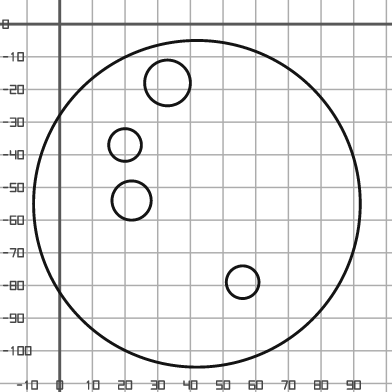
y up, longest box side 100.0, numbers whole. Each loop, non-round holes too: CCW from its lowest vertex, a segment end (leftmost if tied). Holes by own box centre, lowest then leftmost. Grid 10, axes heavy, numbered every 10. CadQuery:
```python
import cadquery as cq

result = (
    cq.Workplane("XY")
    .moveTo(42.0, -55.0)
    .circle(50.0)
    .moveTo(56.0, -79.0)
    .circle(5.0)
    .moveTo(22.0, -54.0)
    .circle(6.0)
    .moveTo(20.0, -37.0)
    .circle(5.0)
    .moveTo(33.0, -18.0)
    .circle(7.0)
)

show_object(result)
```